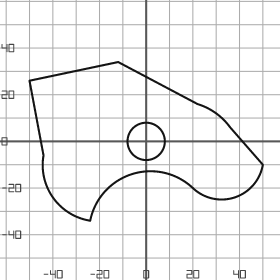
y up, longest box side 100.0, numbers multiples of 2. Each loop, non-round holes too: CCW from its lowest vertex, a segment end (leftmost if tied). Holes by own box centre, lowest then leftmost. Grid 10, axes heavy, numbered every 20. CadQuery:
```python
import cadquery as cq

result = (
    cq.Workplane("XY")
    .moveTo(-24.0, -34.0)
    .threePointArc((-6.0, -14.0), (20.0, -20.0))
    .threePointArc((38.0, -24.0), (50.0, -10.0))
    .lineTo(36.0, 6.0)
    .threePointArc((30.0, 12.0), (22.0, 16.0))
    .lineTo(-12.0, 34.0)
    .lineTo(-50.0, 26.0)
    .lineTo(-44.0, -6.0)
    .threePointArc((-40.0, -24.0), (-24.0, -34.0))
    .close()
    .moveTo(0.0, 0.0)
    .circle(8.0)
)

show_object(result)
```